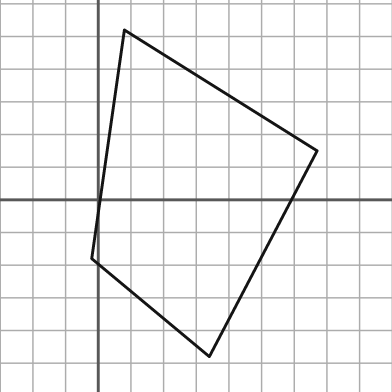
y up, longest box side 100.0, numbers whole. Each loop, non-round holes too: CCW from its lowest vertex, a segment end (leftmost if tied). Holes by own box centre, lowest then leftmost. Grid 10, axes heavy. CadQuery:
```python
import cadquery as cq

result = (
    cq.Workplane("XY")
    .moveTo(34.0, -48.0)
    .lineTo(67.0, 15.0)
    .lineTo(8.0, 52.0)
    .lineTo(-2.0, -18.0)
    .close()
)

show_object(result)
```